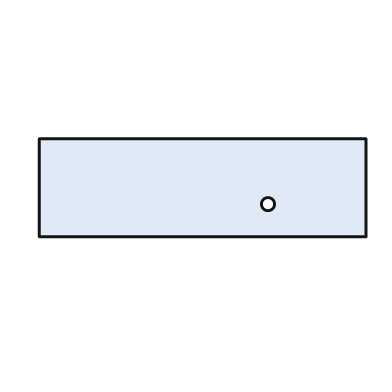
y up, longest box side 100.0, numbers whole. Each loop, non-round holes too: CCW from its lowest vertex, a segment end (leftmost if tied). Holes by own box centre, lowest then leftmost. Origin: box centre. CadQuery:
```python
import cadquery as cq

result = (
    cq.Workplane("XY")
    .moveTo(-50.0, -15.0)
    .lineTo(50.0, -15.0)
    .lineTo(50.0, 15.0)
    .lineTo(-50.0, 15.0)
    .close()
    .moveTo(20.0, -5.0)
    .circle(2.0)
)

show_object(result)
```